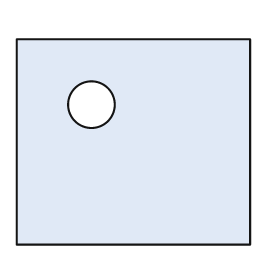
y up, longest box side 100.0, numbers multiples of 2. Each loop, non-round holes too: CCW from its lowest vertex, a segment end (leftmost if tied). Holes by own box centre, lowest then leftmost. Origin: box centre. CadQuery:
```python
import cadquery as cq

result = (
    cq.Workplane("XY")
    .moveTo(-50.0, -44.0)
    .lineTo(50.0, -44.0)
    .lineTo(50.0, 44.0)
    .lineTo(-50.0, 44.0)
    .close()
    .moveTo(-18.0, 16.0)
    .circle(10.0)
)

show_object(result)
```